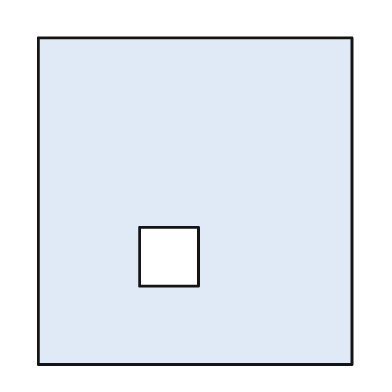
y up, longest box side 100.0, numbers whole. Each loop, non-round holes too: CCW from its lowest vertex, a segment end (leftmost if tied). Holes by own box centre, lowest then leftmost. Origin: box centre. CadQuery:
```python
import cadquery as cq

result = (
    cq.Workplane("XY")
    .moveTo(-48.0, -50.0)
    .lineTo(48.0, -50.0)
    .lineTo(48.0, 50.0)
    .lineTo(-48.0, 50.0)
    .close()
    .moveTo(-17.0, -26.0)
    .lineTo(1.0, -26.0)
    .lineTo(1.0, -8.0)
    .lineTo(-17.0, -8.0)
    .close()
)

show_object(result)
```